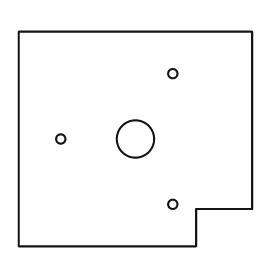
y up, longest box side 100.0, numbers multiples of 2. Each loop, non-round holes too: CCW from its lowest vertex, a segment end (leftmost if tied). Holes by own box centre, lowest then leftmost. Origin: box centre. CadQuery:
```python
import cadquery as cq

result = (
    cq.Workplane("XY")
    .moveTo(-50.0, -46.0)
    .lineTo(26.0, -46.0)
    .lineTo(26.0, -30.0)
    .lineTo(50.0, -30.0)
    .lineTo(50.0, 46.0)
    .lineTo(-50.0, 46.0)
    .close()
    .moveTo(16.0, -28.0)
    .circle(2.0)
    .moveTo(-32.0, 0.0)
    .circle(2.0)
    .moveTo(0.0, 0.0)
    .circle(8.0)
    .moveTo(16.0, 28.0)
    .circle(2.0)
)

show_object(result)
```